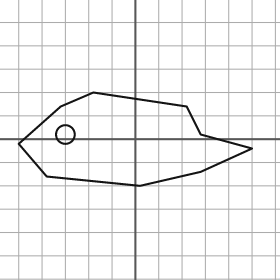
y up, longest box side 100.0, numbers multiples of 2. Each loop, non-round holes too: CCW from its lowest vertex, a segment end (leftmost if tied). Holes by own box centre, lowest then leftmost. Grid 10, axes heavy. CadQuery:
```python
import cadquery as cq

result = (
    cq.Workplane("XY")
    .moveTo(2.0, -20.0)
    .lineTo(28.0, -14.0)
    .lineTo(50.0, -4.0)
    .lineTo(28.0, 2.0)
    .lineTo(22.0, 14.0)
    .lineTo(-18.0, 20.0)
    .lineTo(-32.0, 14.0)
    .lineTo(-50.0, -2.0)
    .lineTo(-38.0, -16.0)
    .close()
    .moveTo(-30.0, 2.0)
    .circle(4.0)
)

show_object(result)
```